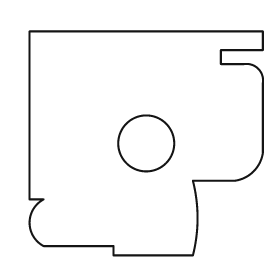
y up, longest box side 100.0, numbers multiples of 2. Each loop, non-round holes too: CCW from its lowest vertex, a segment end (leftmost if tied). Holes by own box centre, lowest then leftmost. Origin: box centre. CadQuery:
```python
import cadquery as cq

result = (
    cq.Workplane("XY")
    .moveTo(-14.0, -48.0)
    .lineTo(20.0, -48.0)
    .threePointArc((22.0, -32.0), (20.0, -16.0))
    .lineTo(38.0, -16.0)
    .threePointArc((46.0, -12.0), (50.0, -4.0))
    .lineTo(50.0, 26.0)
    .threePointArc((48.0, 32.0), (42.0, 34.0))
    .lineTo(32.0, 34.0)
    .lineTo(32.0, 40.0)
    .lineTo(50.0, 40.0)
    .lineTo(50.0, 48.0)
    .lineTo(-50.0, 48.0)
    .lineTo(-50.0, -24.0)
    .lineTo(-44.0, -24.0)
    .threePointArc((-50.0, -34.0), (-44.0, -44.0))
    .lineTo(-14.0, -44.0)
    .close()
    .moveTo(0.0, 0.0)
    .circle(12.0)
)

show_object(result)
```